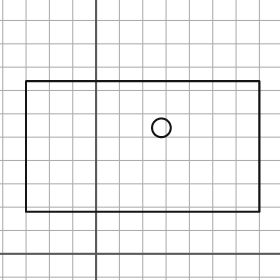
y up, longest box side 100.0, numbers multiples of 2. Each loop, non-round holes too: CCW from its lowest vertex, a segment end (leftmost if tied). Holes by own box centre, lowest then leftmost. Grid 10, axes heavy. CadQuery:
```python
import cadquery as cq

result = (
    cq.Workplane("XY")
    .moveTo(-30.0, 18.0)
    .lineTo(70.0, 18.0)
    .lineTo(70.0, 74.0)
    .lineTo(-30.0, 74.0)
    .close()
    .moveTo(28.0, 54.0)
    .circle(4.0)
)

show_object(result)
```